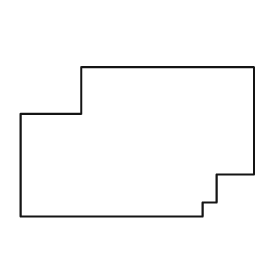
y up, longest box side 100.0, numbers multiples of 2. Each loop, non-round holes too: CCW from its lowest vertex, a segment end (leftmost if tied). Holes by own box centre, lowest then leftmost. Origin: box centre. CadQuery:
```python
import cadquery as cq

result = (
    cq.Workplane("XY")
    .moveTo(-50.0, -32.0)
    .lineTo(28.0, -32.0)
    .lineTo(28.0, -26.0)
    .lineTo(34.0, -26.0)
    .lineTo(34.0, -14.0)
    .lineTo(50.0, -14.0)
    .lineTo(50.0, 32.0)
    .lineTo(-24.0, 32.0)
    .lineTo(-24.0, 12.0)
    .lineTo(-50.0, 12.0)
    .close()
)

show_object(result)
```